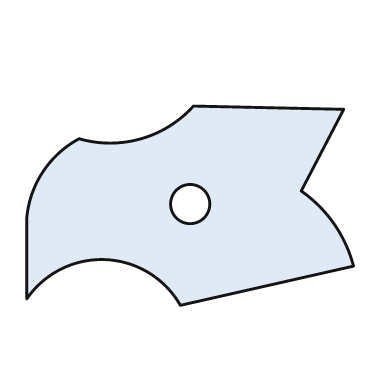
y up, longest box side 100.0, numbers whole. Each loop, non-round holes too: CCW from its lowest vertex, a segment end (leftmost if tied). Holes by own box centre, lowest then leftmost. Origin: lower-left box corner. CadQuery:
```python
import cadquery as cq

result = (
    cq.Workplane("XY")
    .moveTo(47.0, 0.0)
    .lineTo(100.0, 12.0)
    .threePointArc((94.0, 25.0), (84.0, 35.0))
    .lineTo(97.0, 60.0)
    .lineTo(51.0, 61.0)
    .threePointArc((35.0, 51.0), (16.0, 51.0))
    .threePointArc((5.0, 41.0), (0.0, 27.0))
    .lineTo(0.0, 2.0)
    .threePointArc((24.0, 14.0), (47.0, 0.0))
    .close()
    .moveTo(50.0, 31.0)
    .circle(6.0)
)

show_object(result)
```